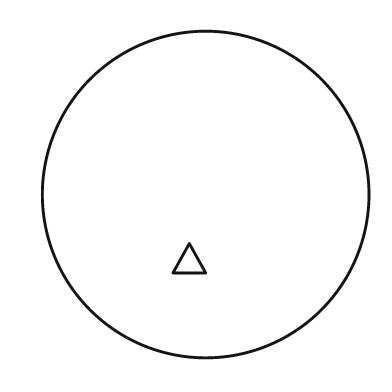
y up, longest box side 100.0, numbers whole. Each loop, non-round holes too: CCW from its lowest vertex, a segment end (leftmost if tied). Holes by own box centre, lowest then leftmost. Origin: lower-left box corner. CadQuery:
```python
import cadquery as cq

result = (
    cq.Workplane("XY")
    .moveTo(50.0, 50.0)
    .circle(50.0)
    .moveTo(40.0, 26.0)
    .lineTo(50.0, 26.0)
    .lineTo(45.0, 35.0)
    .close()
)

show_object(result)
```